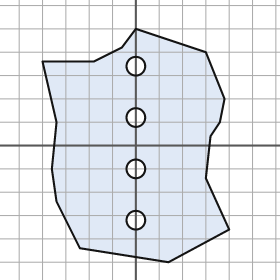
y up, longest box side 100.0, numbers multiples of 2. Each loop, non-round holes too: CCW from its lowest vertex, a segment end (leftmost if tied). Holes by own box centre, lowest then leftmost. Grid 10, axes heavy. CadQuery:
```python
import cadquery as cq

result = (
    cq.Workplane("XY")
    .moveTo(14.0, -50.0)
    .lineTo(40.0, -36.0)
    .lineTo(30.0, -14.0)
    .lineTo(32.0, 4.0)
    .lineTo(36.0, 10.0)
    .lineTo(38.0, 20.0)
    .lineTo(30.0, 40.0)
    .lineTo(0.0, 50.0)
    .lineTo(-6.0, 42.0)
    .lineTo(-18.0, 36.0)
    .lineTo(-40.0, 36.0)
    .lineTo(-34.0, 10.0)
    .lineTo(-36.0, -10.0)
    .lineTo(-34.0, -24.0)
    .lineTo(-24.0, -44.0)
    .close()
    .moveTo(0.0, -32.0)
    .circle(4.0)
    .moveTo(0.0, -10.0)
    .circle(4.0)
    .moveTo(0.0, 12.0)
    .circle(4.0)
    .moveTo(0.0, 34.0)
    .circle(4.0)
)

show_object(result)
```